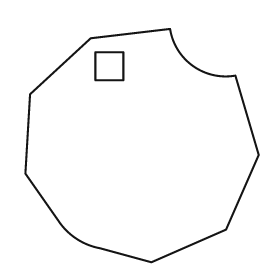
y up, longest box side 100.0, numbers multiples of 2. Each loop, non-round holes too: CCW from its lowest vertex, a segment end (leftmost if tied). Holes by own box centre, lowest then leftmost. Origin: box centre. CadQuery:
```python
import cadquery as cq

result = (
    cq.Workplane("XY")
    .moveTo(4.0, -50.0)
    .lineTo(36.0, -36.0)
    .lineTo(50.0, -4.0)
    .lineTo(40.0, 30.0)
    .threePointArc((22.0, 34.0), (12.0, 50.0))
    .lineTo(-22.0, 46.0)
    .lineTo(-48.0, 22.0)
    .lineTo(-50.0, -12.0)
    .lineTo(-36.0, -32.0)
    .threePointArc((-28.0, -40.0), (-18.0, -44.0))
    .close()
    .moveTo(-20.0, 28.0)
    .lineTo(-8.0, 28.0)
    .lineTo(-8.0, 40.0)
    .lineTo(-20.0, 40.0)
    .close()
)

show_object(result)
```